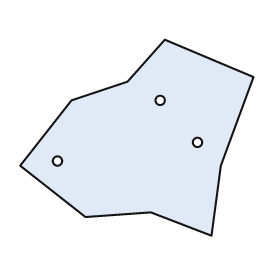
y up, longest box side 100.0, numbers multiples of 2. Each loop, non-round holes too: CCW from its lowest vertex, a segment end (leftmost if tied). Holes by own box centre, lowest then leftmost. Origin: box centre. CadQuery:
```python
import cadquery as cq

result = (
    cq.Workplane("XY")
    .moveTo(32.0, -42.0)
    .lineTo(36.0, -12.0)
    .lineTo(50.0, 26.0)
    .lineTo(12.0, 42.0)
    .lineTo(-4.0, 24.0)
    .lineTo(-28.0, 16.0)
    .lineTo(-50.0, -12.0)
    .lineTo(-22.0, -34.0)
    .lineTo(6.0, -32.0)
    .close()
    .moveTo(-34.0, -10.0)
    .circle(2.0)
    .moveTo(26.0, -2.0)
    .circle(2.0)
    .moveTo(10.0, 16.0)
    .circle(2.0)
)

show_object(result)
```